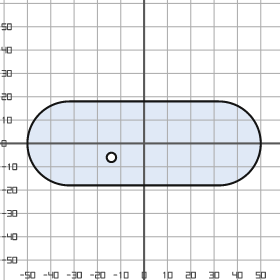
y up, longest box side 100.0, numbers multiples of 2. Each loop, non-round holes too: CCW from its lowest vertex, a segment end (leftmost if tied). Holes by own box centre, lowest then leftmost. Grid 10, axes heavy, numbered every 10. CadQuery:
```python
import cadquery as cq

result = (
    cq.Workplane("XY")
    .moveTo(-32.0, -18.0)
    .lineTo(32.0, -18.0)
    .threePointArc((50.0, 0.0), (32.0, 18.0))
    .lineTo(-32.0, 18.0)
    .threePointArc((-50.0, 0.0), (-32.0, -18.0))
    .close()
    .moveTo(-14.0, -6.0)
    .circle(2.0)
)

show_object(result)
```